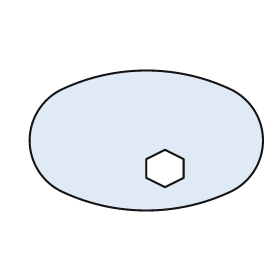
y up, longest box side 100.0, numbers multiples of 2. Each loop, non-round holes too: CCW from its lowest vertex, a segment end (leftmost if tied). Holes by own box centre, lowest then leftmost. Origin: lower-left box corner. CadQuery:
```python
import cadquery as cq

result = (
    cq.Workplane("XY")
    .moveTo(14.0, 8.0)
    .threePointArc((50.0, 0.0), (86.0, 8.0))
    .threePointArc((100.0, 30.0), (86.0, 52.0))
    .threePointArc((50.0, 60.0), (14.0, 52.0))
    .threePointArc((0.0, 30.0), (14.0, 8.0))
    .close()
    .moveTo(58.0, 10.0)
    .lineTo(66.0, 14.0)
    .lineTo(66.0, 22.0)
    .lineTo(58.0, 26.0)
    .lineTo(50.0, 22.0)
    .lineTo(50.0, 14.0)
    .close()
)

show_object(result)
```